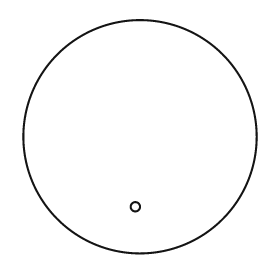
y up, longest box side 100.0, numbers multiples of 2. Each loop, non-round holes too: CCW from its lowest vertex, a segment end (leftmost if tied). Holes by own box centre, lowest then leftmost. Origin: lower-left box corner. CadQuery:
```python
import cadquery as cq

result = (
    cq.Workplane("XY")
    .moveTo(50.0, 50.0)
    .circle(50.0)
    .moveTo(48.0, 20.0)
    .circle(2.0)
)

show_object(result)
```